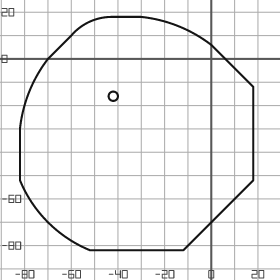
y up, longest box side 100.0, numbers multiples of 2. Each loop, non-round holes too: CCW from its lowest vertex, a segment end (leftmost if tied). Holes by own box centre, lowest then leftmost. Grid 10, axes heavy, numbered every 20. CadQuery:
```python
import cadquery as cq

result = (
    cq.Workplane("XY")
    .moveTo(-52.0, -82.0)
    .lineTo(-12.0, -82.0)
    .lineTo(18.0, -52.0)
    .lineTo(18.0, -12.0)
    .lineTo(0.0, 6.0)
    .threePointArc((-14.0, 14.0), (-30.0, 18.0))
    .lineTo(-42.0, 18.0)
    .threePointArc((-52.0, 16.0), (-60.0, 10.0))
    .lineTo(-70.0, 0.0)
    .threePointArc((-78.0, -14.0), (-82.0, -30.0))
    .lineTo(-82.0, -52.0)
    .threePointArc((-70.0, -70.0), (-52.0, -82.0))
    .close()
    .moveTo(-42.0, -16.0)
    .circle(2.0)
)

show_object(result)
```